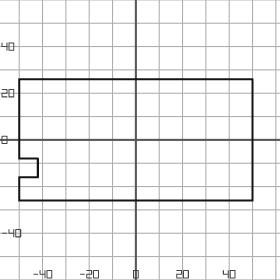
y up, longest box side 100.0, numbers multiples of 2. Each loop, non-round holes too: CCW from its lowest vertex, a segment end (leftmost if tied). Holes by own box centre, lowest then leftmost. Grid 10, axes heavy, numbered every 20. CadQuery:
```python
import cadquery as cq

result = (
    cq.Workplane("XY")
    .moveTo(-50.0, -26.0)
    .lineTo(50.0, -26.0)
    .lineTo(50.0, 26.0)
    .lineTo(-50.0, 26.0)
    .lineTo(-50.0, -8.0)
    .lineTo(-42.0, -8.0)
    .lineTo(-42.0, -16.0)
    .lineTo(-50.0, -16.0)
    .close()
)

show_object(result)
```